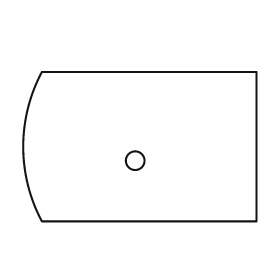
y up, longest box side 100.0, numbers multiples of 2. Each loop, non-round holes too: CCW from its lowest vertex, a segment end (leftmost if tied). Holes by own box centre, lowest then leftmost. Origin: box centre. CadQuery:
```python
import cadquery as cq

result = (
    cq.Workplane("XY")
    .moveTo(-42.0, -32.0)
    .lineTo(50.0, -32.0)
    .lineTo(50.0, 32.0)
    .lineTo(-42.0, 32.0)
    .threePointArc((-50.0, 0.0), (-42.0, -32.0))
    .close()
    .moveTo(-2.0, -6.0)
    .circle(4.0)
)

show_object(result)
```